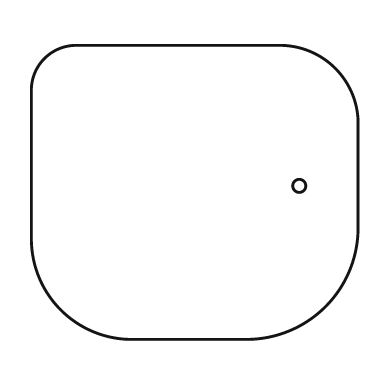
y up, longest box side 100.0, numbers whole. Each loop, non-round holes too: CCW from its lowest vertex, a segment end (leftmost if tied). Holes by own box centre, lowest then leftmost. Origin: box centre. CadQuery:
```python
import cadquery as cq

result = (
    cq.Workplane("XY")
    .moveTo(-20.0, -45.0)
    .lineTo(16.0, -45.0)
    .threePointArc((40.0, -35.0), (50.0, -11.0))
    .lineTo(50.0, 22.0)
    .threePointArc((43.0, 38.0), (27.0, 45.0))
    .lineTo(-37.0, 45.0)
    .threePointArc((-46.0, 41.0), (-50.0, 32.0))
    .lineTo(-50.0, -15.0)
    .threePointArc((-41.0, -36.0), (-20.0, -45.0))
    .close()
    .moveTo(32.0, 2.0)
    .circle(2.0)
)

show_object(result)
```